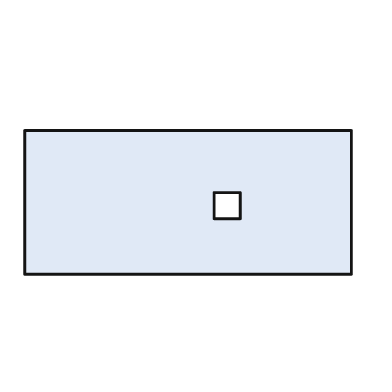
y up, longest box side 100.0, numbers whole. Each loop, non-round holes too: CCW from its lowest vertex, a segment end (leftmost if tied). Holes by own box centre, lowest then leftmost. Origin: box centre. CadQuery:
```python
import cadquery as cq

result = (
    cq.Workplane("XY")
    .moveTo(-50.0, -22.0)
    .lineTo(50.0, -22.0)
    .lineTo(50.0, 22.0)
    .lineTo(-50.0, 22.0)
    .close()
    .moveTo(8.0, -5.0)
    .lineTo(16.0, -5.0)
    .lineTo(16.0, 3.0)
    .lineTo(8.0, 3.0)
    .close()
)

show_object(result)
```